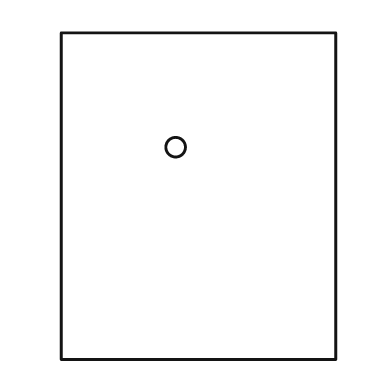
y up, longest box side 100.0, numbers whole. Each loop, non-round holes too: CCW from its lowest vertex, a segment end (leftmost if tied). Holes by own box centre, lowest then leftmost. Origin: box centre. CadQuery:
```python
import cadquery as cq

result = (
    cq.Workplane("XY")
    .moveTo(-42.0, -50.0)
    .lineTo(42.0, -50.0)
    .lineTo(42.0, 50.0)
    .lineTo(-42.0, 50.0)
    .close()
    .moveTo(-7.0, 15.0)
    .circle(3.0)
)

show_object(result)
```